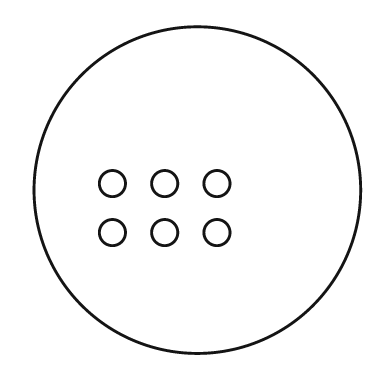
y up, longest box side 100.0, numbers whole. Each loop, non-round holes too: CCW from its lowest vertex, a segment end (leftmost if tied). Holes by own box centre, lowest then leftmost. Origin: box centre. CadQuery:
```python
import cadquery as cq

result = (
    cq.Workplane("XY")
    .moveTo(0.0, 0.0)
    .circle(50.0)
    .moveTo(-26.0, -13.0)
    .circle(4.0)
    .moveTo(-10.0, -13.0)
    .circle(4.0)
    .moveTo(6.0, -13.0)
    .circle(4.0)
    .moveTo(-26.0, 2.0)
    .circle(4.0)
    .moveTo(-10.0, 2.0)
    .circle(4.0)
    .moveTo(6.0, 2.0)
    .circle(4.0)
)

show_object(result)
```